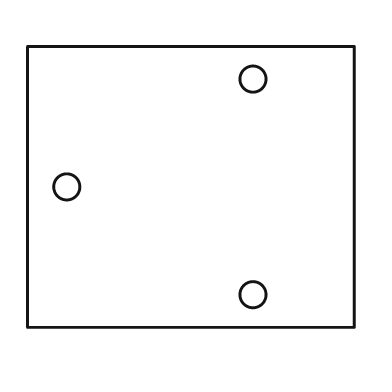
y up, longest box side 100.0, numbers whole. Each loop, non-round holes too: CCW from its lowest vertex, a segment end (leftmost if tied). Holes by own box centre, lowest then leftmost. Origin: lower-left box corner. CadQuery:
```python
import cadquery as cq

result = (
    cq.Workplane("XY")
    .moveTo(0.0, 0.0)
    .lineTo(100.0, 0.0)
    .lineTo(100.0, 86.0)
    .lineTo(0.0, 86.0)
    .close()
    .moveTo(69.0, 10.0)
    .circle(4.0)
    .moveTo(12.0, 43.0)
    .circle(4.0)
    .moveTo(69.0, 76.0)
    .circle(4.0)
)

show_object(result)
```